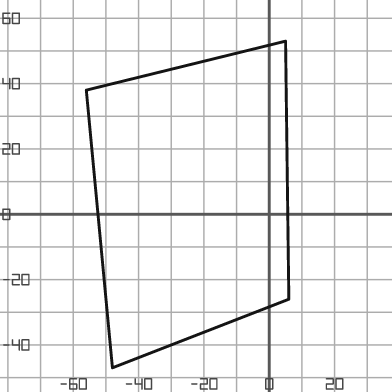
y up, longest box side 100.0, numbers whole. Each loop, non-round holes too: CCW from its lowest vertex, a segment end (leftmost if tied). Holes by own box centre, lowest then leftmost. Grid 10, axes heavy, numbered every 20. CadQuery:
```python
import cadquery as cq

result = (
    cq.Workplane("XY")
    .moveTo(-48.0, -47.0)
    .lineTo(6.0, -26.0)
    .lineTo(5.0, 53.0)
    .lineTo(-56.0, 38.0)
    .close()
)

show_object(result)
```